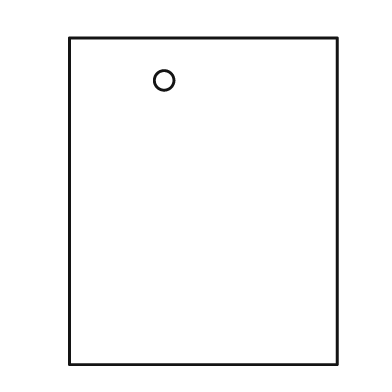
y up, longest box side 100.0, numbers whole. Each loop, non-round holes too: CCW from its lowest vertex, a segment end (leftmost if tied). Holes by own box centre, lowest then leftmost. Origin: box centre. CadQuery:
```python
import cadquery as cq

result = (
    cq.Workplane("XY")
    .moveTo(-41.0, -50.0)
    .lineTo(41.0, -50.0)
    .lineTo(41.0, 50.0)
    .lineTo(-41.0, 50.0)
    .close()
    .moveTo(-12.0, 37.0)
    .circle(3.0)
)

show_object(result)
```